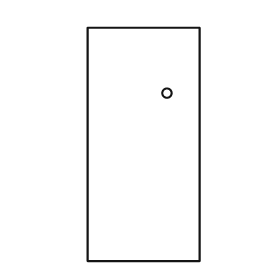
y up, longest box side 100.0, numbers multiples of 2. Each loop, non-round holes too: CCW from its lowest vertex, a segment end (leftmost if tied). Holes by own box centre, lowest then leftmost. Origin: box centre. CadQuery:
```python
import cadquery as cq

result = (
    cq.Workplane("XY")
    .moveTo(-24.0, -50.0)
    .lineTo(24.0, -50.0)
    .lineTo(24.0, 50.0)
    .lineTo(-24.0, 50.0)
    .close()
    .moveTo(10.0, 22.0)
    .circle(2.0)
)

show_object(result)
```